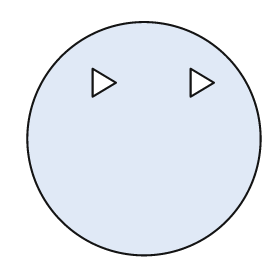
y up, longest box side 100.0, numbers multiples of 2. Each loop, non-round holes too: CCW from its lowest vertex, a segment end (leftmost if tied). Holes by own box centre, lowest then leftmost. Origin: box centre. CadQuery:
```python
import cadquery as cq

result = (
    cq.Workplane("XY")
    .moveTo(0.0, 0.0)
    .circle(50.0)
    .moveTo(-22.0, 18.0)
    .lineTo(-12.0, 24.0)
    .lineTo(-22.0, 30.0)
    .close()
    .moveTo(20.0, 18.0)
    .lineTo(30.0, 24.0)
    .lineTo(20.0, 30.0)
    .close()
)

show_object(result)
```